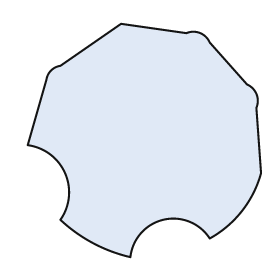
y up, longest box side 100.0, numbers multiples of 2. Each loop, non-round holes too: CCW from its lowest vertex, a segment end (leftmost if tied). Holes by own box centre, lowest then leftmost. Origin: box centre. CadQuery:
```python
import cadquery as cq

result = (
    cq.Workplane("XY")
    .moveTo(-6.0, -50.0)
    .threePointArc((8.0, -34.0), (28.0, -42.0))
    .threePointArc((42.0, -30.0), (50.0, -14.0))
    .lineTo(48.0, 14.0)
    .threePointArc((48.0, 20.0), (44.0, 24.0))
    .lineTo(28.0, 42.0)
    .threePointArc((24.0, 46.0), (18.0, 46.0))
    .lineTo(-10.0, 50.0)
    .lineTo(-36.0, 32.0)
    .threePointArc((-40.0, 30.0), (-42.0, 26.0))
    .lineTo(-50.0, -2.0)
    .threePointArc((-34.0, -14.0), (-36.0, -34.0))
    .threePointArc((-22.0, -44.0), (-6.0, -50.0))
    .close()
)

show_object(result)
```